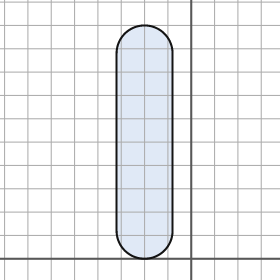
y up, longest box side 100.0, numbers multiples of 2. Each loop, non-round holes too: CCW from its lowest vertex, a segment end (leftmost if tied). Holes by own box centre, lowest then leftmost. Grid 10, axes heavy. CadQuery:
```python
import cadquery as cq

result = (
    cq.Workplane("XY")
    .moveTo(-32.0, 12.0)
    .threePointArc((-20.0, 0.0), (-8.0, 12.0))
    .lineTo(-8.0, 88.0)
    .threePointArc((-20.0, 100.0), (-32.0, 88.0))
    .close()
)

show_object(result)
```